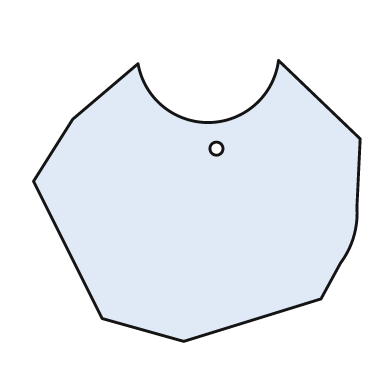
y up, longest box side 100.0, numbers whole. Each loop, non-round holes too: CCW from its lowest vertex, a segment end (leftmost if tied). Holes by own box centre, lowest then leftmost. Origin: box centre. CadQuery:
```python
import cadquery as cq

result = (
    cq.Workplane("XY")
    .moveTo(-4.0, -43.0)
    .lineTo(38.0, -30.0)
    .lineTo(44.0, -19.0)
    .threePointArc((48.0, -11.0), (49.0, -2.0))
    .lineTo(50.0, 19.0)
    .lineTo(25.0, 43.0)
    .threePointArc((4.0, 24.0), (-18.0, 42.0))
    .lineTo(-38.0, 25.0)
    .lineTo(-50.0, 6.0)
    .lineTo(-29.0, -36.0)
    .close()
    .moveTo(6.0, 16.0)
    .circle(2.0)
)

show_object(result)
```